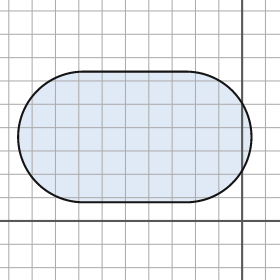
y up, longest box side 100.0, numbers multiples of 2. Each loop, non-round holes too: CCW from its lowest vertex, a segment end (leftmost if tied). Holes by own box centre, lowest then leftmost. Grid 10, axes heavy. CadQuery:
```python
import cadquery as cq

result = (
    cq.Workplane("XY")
    .moveTo(-68.0, 8.0)
    .lineTo(-24.0, 8.0)
    .threePointArc((4.0, 36.0), (-24.0, 64.0))
    .lineTo(-68.0, 64.0)
    .threePointArc((-96.0, 36.0), (-68.0, 8.0))
    .close()
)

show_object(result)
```